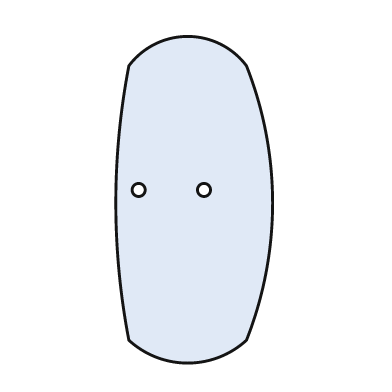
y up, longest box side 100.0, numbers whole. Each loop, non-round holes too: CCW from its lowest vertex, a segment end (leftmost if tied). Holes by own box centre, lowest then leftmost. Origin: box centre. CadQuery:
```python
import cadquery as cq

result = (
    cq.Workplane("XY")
    .moveTo(-20.0, -43.0)
    .threePointArc((-2.0, -50.0), (16.0, -43.0))
    .threePointArc((24.0, -1.0), (16.0, 41.0))
    .threePointArc((-2.0, 50.0), (-20.0, 41.0))
    .threePointArc((-24.0, -1.0), (-20.0, -43.0))
    .close()
    .moveTo(-17.0, 3.0)
    .circle(2.0)
    .moveTo(3.0, 3.0)
    .circle(2.0)
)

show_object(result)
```